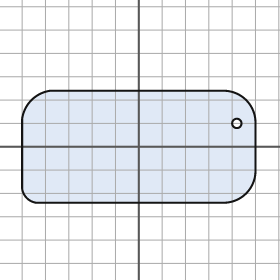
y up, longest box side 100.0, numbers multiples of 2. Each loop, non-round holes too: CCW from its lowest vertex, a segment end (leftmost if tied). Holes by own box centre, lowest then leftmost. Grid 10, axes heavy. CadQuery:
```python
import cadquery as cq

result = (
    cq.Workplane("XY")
    .moveTo(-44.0, -24.0)
    .lineTo(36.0, -24.0)
    .threePointArc((46.0, -20.0), (50.0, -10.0))
    .lineTo(50.0, 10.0)
    .threePointArc((46.0, 20.0), (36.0, 24.0))
    .lineTo(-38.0, 24.0)
    .threePointArc((-46.0, 20.0), (-50.0, 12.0))
    .lineTo(-50.0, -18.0)
    .threePointArc((-48.0, -22.0), (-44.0, -24.0))
    .close()
    .moveTo(42.0, 10.0)
    .circle(2.0)
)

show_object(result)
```